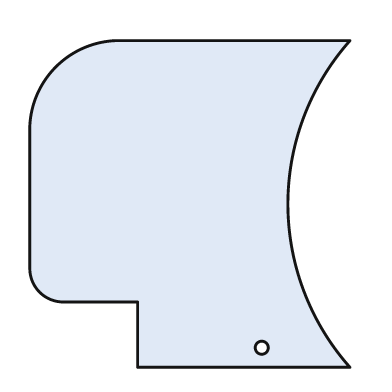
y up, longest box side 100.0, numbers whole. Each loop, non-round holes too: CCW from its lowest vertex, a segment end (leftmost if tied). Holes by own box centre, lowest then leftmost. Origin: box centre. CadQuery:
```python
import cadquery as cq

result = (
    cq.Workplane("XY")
    .moveTo(-16.0, -50.0)
    .lineTo(49.0, -50.0)
    .threePointArc((30.0, 0.0), (49.0, 50.0))
    .lineTo(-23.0, 50.0)
    .threePointArc((-41.0, 42.0), (-49.0, 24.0))
    .lineTo(-49.0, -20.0)
    .threePointArc((-46.0, -27.0), (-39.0, -30.0))
    .lineTo(-16.0, -30.0)
    .close()
    .moveTo(22.0, -44.0)
    .circle(2.0)
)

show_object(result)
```